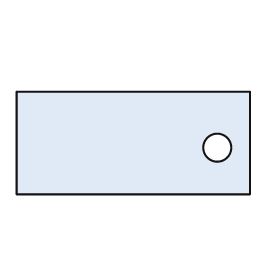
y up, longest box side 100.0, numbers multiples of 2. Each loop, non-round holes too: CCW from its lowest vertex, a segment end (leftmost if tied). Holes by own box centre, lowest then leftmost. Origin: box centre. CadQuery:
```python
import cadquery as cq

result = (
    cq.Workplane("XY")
    .moveTo(-50.0, -22.0)
    .lineTo(50.0, -22.0)
    .lineTo(50.0, 22.0)
    .lineTo(-50.0, 22.0)
    .close()
    .moveTo(36.0, -2.0)
    .circle(6.0)
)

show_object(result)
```